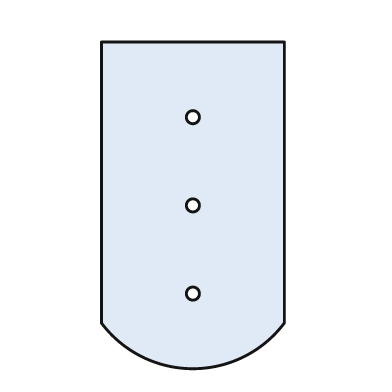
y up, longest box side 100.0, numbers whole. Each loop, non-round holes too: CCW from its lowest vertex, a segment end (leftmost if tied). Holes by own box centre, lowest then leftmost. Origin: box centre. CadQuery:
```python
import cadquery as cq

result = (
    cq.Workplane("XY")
    .moveTo(-28.0, -36.0)
    .threePointArc((0.0, -50.0), (28.0, -36.0))
    .lineTo(28.0, 50.0)
    .lineTo(-28.0, 50.0)
    .close()
    .moveTo(0.0, -27.0)
    .circle(2.0)
    .moveTo(0.0, 0.0)
    .circle(2.0)
    .moveTo(0.0, 27.0)
    .circle(2.0)
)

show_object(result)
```